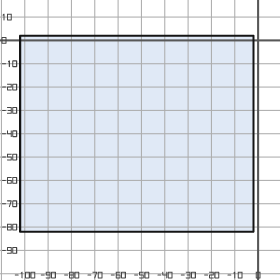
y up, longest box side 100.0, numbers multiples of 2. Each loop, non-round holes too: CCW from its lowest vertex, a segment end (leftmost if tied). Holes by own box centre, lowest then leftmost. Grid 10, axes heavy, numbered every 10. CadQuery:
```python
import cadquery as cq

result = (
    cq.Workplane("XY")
    .moveTo(-102.0, -82.0)
    .lineTo(-2.0, -82.0)
    .lineTo(-2.0, 2.0)
    .lineTo(-102.0, 2.0)
    .close()
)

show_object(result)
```